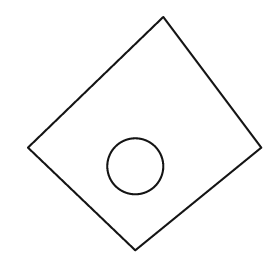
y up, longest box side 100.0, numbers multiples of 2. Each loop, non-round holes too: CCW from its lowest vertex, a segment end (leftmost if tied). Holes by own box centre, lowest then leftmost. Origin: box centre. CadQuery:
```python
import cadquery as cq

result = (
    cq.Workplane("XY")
    .moveTo(-4.0, -50.0)
    .lineTo(50.0, -6.0)
    .lineTo(8.0, 50.0)
    .lineTo(-50.0, -6.0)
    .close()
    .moveTo(-4.0, -14.0)
    .circle(12.0)
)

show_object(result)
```